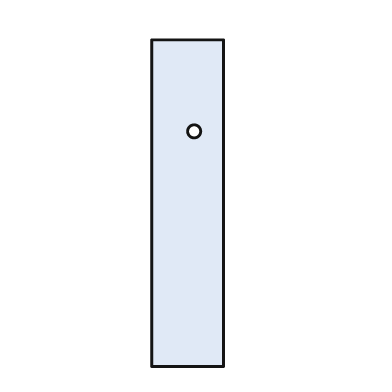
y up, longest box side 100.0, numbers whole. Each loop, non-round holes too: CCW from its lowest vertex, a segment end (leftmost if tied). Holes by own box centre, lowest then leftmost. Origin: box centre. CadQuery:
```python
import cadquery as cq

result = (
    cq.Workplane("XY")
    .moveTo(-11.0, -50.0)
    .lineTo(11.0, -50.0)
    .lineTo(11.0, 50.0)
    .lineTo(-11.0, 50.0)
    .close()
    .moveTo(2.0, 22.0)
    .circle(2.0)
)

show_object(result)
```